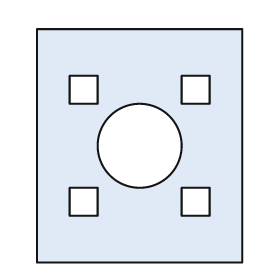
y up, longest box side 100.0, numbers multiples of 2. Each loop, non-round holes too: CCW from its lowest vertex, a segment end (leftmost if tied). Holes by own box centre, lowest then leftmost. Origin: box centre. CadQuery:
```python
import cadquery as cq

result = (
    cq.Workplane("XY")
    .moveTo(-44.0, -50.0)
    .lineTo(44.0, -50.0)
    .lineTo(44.0, 50.0)
    .lineTo(-44.0, 50.0)
    .close()
    .moveTo(-30.0, -30.0)
    .lineTo(-18.0, -30.0)
    .lineTo(-18.0, -18.0)
    .lineTo(-30.0, -18.0)
    .close()
    .moveTo(18.0, -30.0)
    .lineTo(30.0, -30.0)
    .lineTo(30.0, -18.0)
    .lineTo(18.0, -18.0)
    .close()
    .moveTo(0.0, 0.0)
    .circle(18.0)
    .moveTo(-30.0, 18.0)
    .lineTo(-18.0, 18.0)
    .lineTo(-18.0, 30.0)
    .lineTo(-30.0, 30.0)
    .close()
    .moveTo(18.0, 18.0)
    .lineTo(30.0, 18.0)
    .lineTo(30.0, 30.0)
    .lineTo(18.0, 30.0)
    .close()
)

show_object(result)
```